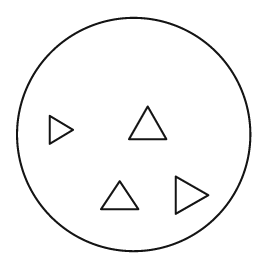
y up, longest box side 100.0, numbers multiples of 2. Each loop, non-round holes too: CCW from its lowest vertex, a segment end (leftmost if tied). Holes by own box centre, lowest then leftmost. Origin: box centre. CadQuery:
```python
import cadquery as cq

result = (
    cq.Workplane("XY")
    .moveTo(0.0, 0.0)
    .circle(50.0)
    .moveTo(-14.0, -32.0)
    .lineTo(2.0, -32.0)
    .lineTo(-6.0, -20.0)
    .close()
    .moveTo(18.0, -34.0)
    .lineTo(32.0, -26.0)
    .lineTo(18.0, -18.0)
    .close()
    .moveTo(-36.0, -4.0)
    .lineTo(-26.0, 2.0)
    .lineTo(-36.0, 8.0)
    .close()
    .moveTo(-2.0, -2.0)
    .lineTo(14.0, -2.0)
    .lineTo(6.0, 12.0)
    .close()
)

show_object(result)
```